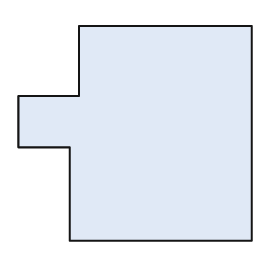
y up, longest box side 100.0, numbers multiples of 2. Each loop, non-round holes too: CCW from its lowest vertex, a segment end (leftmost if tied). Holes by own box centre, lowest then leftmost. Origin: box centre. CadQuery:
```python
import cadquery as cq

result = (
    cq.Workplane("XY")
    .moveTo(-28.0, -46.0)
    .lineTo(50.0, -46.0)
    .lineTo(50.0, 46.0)
    .lineTo(-24.0, 46.0)
    .lineTo(-24.0, 16.0)
    .lineTo(-50.0, 16.0)
    .lineTo(-50.0, -6.0)
    .lineTo(-28.0, -6.0)
    .close()
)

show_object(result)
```